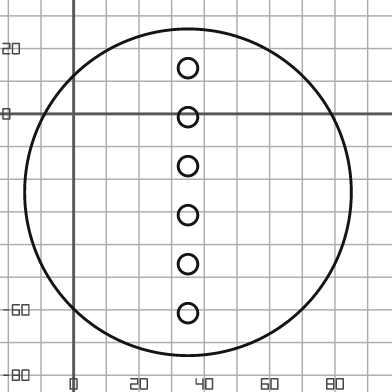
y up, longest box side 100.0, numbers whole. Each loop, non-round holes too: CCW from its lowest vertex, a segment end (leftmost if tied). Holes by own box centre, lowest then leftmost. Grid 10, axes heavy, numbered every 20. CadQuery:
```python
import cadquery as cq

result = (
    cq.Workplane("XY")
    .moveTo(35.0, -24.0)
    .circle(50.0)
    .moveTo(35.0, -61.0)
    .circle(3.0)
    .moveTo(35.0, -46.0)
    .circle(3.0)
    .moveTo(35.0, -31.0)
    .circle(3.0)
    .moveTo(35.0, -16.0)
    .circle(3.0)
    .moveTo(35.0, -1.0)
    .circle(3.0)
    .moveTo(35.0, 14.0)
    .circle(3.0)
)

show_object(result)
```